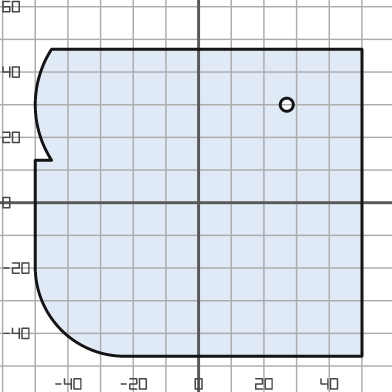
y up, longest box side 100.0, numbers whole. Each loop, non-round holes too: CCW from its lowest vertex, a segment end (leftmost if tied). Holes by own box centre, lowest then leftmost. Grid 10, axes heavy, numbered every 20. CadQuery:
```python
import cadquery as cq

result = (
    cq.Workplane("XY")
    .moveTo(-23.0, -47.0)
    .lineTo(50.0, -47.0)
    .lineTo(50.0, 47.0)
    .lineTo(-45.0, 47.0)
    .threePointArc((-50.0, 30.0), (-45.0, 13.0))
    .lineTo(-50.0, 13.0)
    .lineTo(-50.0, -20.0)
    .threePointArc((-42.0, -39.0), (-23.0, -47.0))
    .close()
    .moveTo(27.0, 30.0)
    .circle(2.0)
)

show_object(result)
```